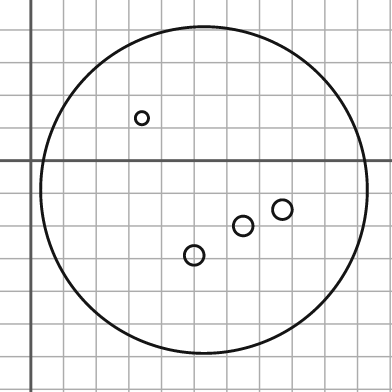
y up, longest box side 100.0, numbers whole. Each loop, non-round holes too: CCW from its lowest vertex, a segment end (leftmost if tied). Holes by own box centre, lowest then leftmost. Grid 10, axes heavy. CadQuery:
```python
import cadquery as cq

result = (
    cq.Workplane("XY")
    .moveTo(53.0, -9.0)
    .circle(50.0)
    .moveTo(50.0, -29.0)
    .circle(3.0)
    .moveTo(65.0, -20.0)
    .circle(3.0)
    .moveTo(77.0, -15.0)
    .circle(3.0)
    .moveTo(34.0, 13.0)
    .circle(2.0)
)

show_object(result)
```